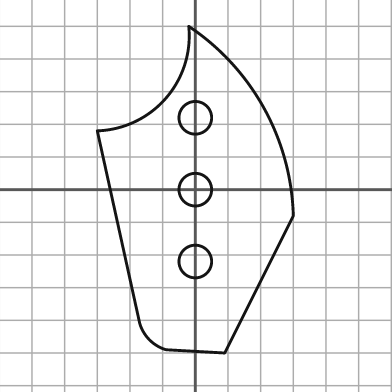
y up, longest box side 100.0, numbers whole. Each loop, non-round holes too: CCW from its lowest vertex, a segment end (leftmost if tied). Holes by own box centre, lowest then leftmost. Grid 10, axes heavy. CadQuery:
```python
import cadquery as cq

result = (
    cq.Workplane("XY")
    .moveTo(9.0, -50.0)
    .lineTo(30.0, -8.0)
    .threePointArc((21.0, 25.0), (-2.0, 50.0))
    .threePointArc((-9.0, 28.0), (-30.0, 18.0))
    .lineTo(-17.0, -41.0)
    .threePointArc((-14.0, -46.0), (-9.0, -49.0))
    .close()
    .moveTo(0.0, -22.0)
    .circle(5.0)
    .moveTo(0.0, 0.0)
    .circle(5.0)
    .moveTo(0.0, 22.0)
    .circle(5.0)
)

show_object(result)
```